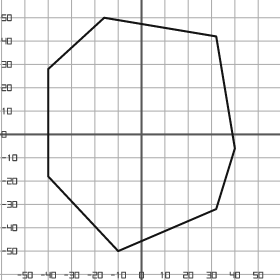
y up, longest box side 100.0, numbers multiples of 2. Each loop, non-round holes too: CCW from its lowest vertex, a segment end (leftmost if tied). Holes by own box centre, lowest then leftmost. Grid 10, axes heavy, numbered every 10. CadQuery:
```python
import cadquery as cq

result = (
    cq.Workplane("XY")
    .moveTo(-10.0, -50.0)
    .lineTo(32.0, -32.0)
    .lineTo(40.0, -6.0)
    .lineTo(32.0, 42.0)
    .lineTo(-16.0, 50.0)
    .lineTo(-40.0, 28.0)
    .lineTo(-40.0, -18.0)
    .close()
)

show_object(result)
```